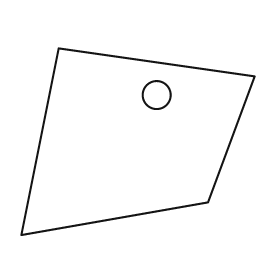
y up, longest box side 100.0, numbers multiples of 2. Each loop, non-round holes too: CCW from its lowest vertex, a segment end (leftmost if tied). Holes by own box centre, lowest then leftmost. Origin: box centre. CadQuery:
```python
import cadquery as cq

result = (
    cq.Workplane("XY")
    .moveTo(-50.0, -40.0)
    .lineTo(30.0, -26.0)
    .lineTo(50.0, 28.0)
    .lineTo(-34.0, 40.0)
    .close()
    .moveTo(8.0, 20.0)
    .circle(6.0)
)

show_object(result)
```